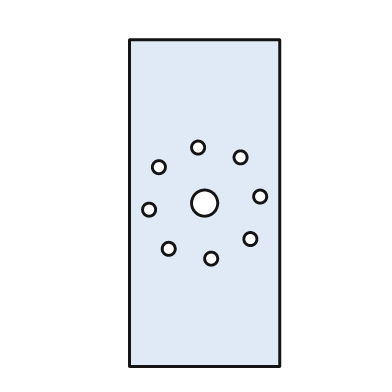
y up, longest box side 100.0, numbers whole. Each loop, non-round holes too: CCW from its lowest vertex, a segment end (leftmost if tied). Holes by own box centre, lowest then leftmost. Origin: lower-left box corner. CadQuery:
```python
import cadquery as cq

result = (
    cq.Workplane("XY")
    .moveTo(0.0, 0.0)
    .lineTo(46.0, 0.0)
    .lineTo(46.0, 100.0)
    .lineTo(0.0, 100.0)
    .close()
    .moveTo(25.0, 33.0)
    .circle(2.0)
    .moveTo(12.0, 36.0)
    .circle(2.0)
    .moveTo(37.0, 39.0)
    .circle(2.0)
    .moveTo(6.0, 48.0)
    .circle(2.0)
    .moveTo(23.0, 50.0)
    .circle(4.0)
    .moveTo(40.0, 52.0)
    .circle(2.0)
    .moveTo(9.0, 61.0)
    .circle(2.0)
    .moveTo(34.0, 64.0)
    .circle(2.0)
    .moveTo(21.0, 67.0)
    .circle(2.0)
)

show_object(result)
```